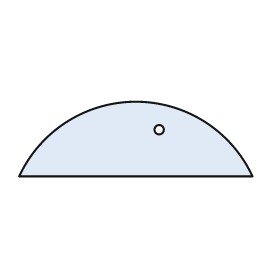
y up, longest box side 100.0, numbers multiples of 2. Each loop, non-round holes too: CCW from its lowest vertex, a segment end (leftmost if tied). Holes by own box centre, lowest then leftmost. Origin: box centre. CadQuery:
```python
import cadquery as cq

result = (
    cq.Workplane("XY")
    .moveTo(-50.0, -16.0)
    .lineTo(50.0, -16.0)
    .threePointArc((0.0, 16.0), (-50.0, -16.0))
    .close()
    .moveTo(10.0, 4.0)
    .circle(2.0)
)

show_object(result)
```